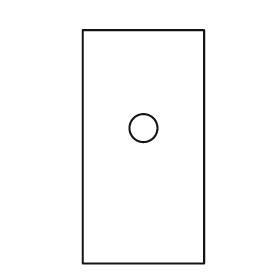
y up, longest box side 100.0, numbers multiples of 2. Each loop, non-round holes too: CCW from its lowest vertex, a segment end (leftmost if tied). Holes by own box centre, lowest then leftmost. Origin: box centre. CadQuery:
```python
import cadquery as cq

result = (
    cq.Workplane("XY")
    .moveTo(-26.0, -50.0)
    .lineTo(26.0, -50.0)
    .lineTo(26.0, 50.0)
    .lineTo(-26.0, 50.0)
    .close()
    .moveTo(0.0, 8.0)
    .circle(6.0)
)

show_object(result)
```